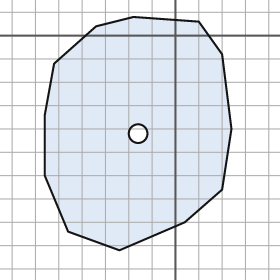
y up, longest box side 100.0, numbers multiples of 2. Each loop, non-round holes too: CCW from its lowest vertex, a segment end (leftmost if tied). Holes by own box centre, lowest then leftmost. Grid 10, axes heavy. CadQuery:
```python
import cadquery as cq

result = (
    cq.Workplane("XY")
    .moveTo(-24.0, -92.0)
    .lineTo(4.0, -80.0)
    .lineTo(20.0, -66.0)
    .lineTo(24.0, -40.0)
    .lineTo(20.0, -8.0)
    .lineTo(10.0, 6.0)
    .lineTo(-18.0, 8.0)
    .lineTo(-34.0, 4.0)
    .lineTo(-52.0, -12.0)
    .lineTo(-56.0, -34.0)
    .lineTo(-56.0, -60.0)
    .lineTo(-46.0, -84.0)
    .close()
    .moveTo(-16.0, -42.0)
    .circle(4.0)
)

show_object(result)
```